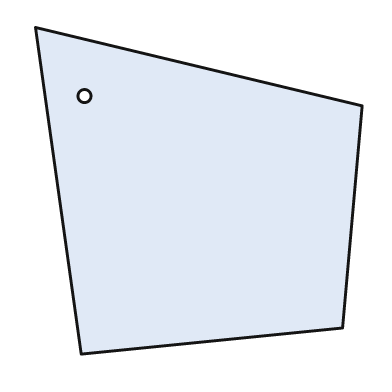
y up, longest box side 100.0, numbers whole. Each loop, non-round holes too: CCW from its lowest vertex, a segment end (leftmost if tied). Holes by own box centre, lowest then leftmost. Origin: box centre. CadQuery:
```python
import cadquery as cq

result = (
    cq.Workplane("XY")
    .moveTo(-36.0, -50.0)
    .lineTo(44.0, -42.0)
    .lineTo(50.0, 26.0)
    .lineTo(-50.0, 50.0)
    .close()
    .moveTo(-35.0, 29.0)
    .circle(2.0)
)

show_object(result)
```